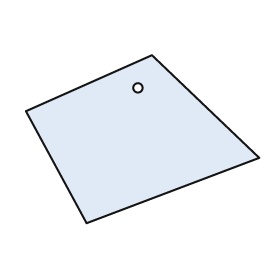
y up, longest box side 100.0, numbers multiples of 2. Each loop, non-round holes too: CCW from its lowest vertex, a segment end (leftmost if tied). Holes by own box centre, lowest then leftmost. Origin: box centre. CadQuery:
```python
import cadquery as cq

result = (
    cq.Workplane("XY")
    .moveTo(-24.0, -36.0)
    .lineTo(50.0, -8.0)
    .lineTo(4.0, 36.0)
    .lineTo(-50.0, 12.0)
    .close()
    .moveTo(-2.0, 22.0)
    .circle(2.0)
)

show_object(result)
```